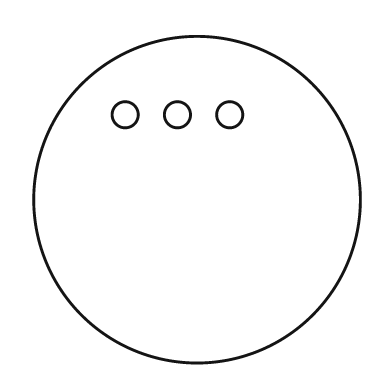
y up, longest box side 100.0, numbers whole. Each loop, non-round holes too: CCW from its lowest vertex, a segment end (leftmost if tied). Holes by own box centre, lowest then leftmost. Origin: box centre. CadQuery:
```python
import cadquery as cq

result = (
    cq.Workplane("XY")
    .moveTo(0.0, 0.0)
    .circle(50.0)
    .moveTo(-22.0, 26.0)
    .circle(4.0)
    .moveTo(-6.0, 26.0)
    .circle(4.0)
    .moveTo(10.0, 26.0)
    .circle(4.0)
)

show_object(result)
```